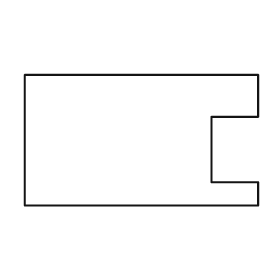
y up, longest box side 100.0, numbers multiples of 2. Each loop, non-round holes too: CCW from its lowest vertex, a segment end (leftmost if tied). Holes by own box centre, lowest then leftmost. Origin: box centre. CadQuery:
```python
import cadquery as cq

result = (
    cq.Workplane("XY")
    .moveTo(-50.0, -28.0)
    .lineTo(50.0, -28.0)
    .lineTo(50.0, -18.0)
    .lineTo(30.0, -18.0)
    .lineTo(30.0, 10.0)
    .lineTo(50.0, 10.0)
    .lineTo(50.0, 28.0)
    .lineTo(-50.0, 28.0)
    .close()
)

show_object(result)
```